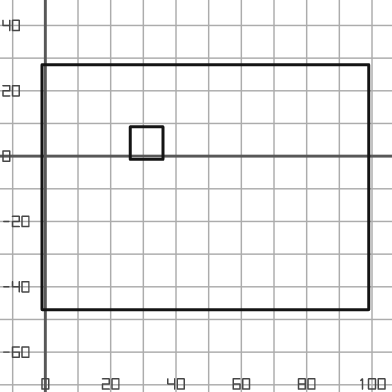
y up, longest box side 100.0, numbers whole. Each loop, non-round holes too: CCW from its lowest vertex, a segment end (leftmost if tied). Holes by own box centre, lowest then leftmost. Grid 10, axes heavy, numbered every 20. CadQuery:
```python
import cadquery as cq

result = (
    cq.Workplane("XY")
    .moveTo(-1.0, -47.0)
    .lineTo(99.0, -47.0)
    .lineTo(99.0, 28.0)
    .lineTo(-1.0, 28.0)
    .close()
    .moveTo(26.0, -1.0)
    .lineTo(36.0, -1.0)
    .lineTo(36.0, 9.0)
    .lineTo(26.0, 9.0)
    .close()
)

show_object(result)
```